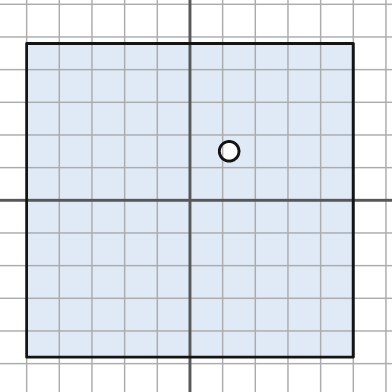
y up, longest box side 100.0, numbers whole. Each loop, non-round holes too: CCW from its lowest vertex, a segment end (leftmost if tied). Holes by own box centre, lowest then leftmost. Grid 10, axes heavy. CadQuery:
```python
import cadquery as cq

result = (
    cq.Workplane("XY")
    .moveTo(-50.0, -48.0)
    .lineTo(50.0, -48.0)
    .lineTo(50.0, 48.0)
    .lineTo(-50.0, 48.0)
    .close()
    .moveTo(12.0, 15.0)
    .circle(3.0)
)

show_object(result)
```